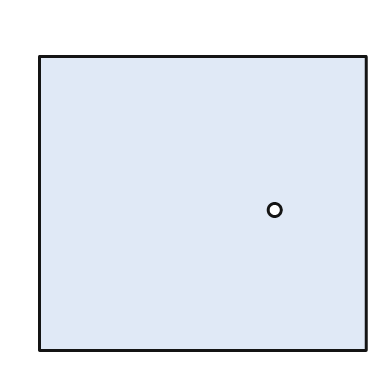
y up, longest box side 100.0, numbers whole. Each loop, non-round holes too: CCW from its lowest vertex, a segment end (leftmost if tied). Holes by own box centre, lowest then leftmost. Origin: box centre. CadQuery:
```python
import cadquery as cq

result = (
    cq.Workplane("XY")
    .moveTo(-50.0, -45.0)
    .lineTo(50.0, -45.0)
    .lineTo(50.0, 45.0)
    .lineTo(-50.0, 45.0)
    .close()
    .moveTo(22.0, -2.0)
    .circle(2.0)
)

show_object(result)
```